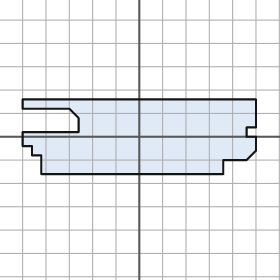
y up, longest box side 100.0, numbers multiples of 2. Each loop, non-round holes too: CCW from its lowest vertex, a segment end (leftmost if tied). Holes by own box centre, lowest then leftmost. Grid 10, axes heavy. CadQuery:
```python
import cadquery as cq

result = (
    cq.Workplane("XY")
    .moveTo(-42.0, -16.0)
    .lineTo(36.0, -16.0)
    .lineTo(36.0, -10.0)
    .lineTo(46.0, -10.0)
    .lineTo(50.0, -6.0)
    .lineTo(50.0, 0.0)
    .lineTo(46.0, 0.0)
    .lineTo(46.0, 4.0)
    .lineTo(50.0, 4.0)
    .lineTo(50.0, 16.0)
    .lineTo(-50.0, 16.0)
    .lineTo(-50.0, 12.0)
    .lineTo(-30.0, 12.0)
    .lineTo(-26.0, 8.0)
    .lineTo(-26.0, 2.0)
    .lineTo(-50.0, 2.0)
    .lineTo(-50.0, -4.0)
    .lineTo(-46.0, -4.0)
    .lineTo(-46.0, -8.0)
    .lineTo(-42.0, -8.0)
    .close()
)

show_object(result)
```